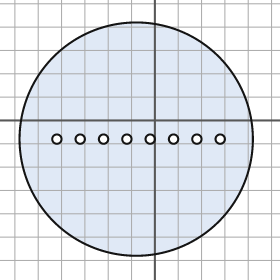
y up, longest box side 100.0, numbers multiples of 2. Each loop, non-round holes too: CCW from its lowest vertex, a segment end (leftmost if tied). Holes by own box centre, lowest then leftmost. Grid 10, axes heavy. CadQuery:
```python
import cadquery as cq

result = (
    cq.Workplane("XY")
    .moveTo(-8.0, -8.0)
    .circle(50.0)
    .moveTo(-42.0, -8.0)
    .circle(2.0)
    .moveTo(-32.0, -8.0)
    .circle(2.0)
    .moveTo(-22.0, -8.0)
    .circle(2.0)
    .moveTo(-12.0, -8.0)
    .circle(2.0)
    .moveTo(-2.0, -8.0)
    .circle(2.0)
    .moveTo(8.0, -8.0)
    .circle(2.0)
    .moveTo(18.0, -8.0)
    .circle(2.0)
    .moveTo(28.0, -8.0)
    .circle(2.0)
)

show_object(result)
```